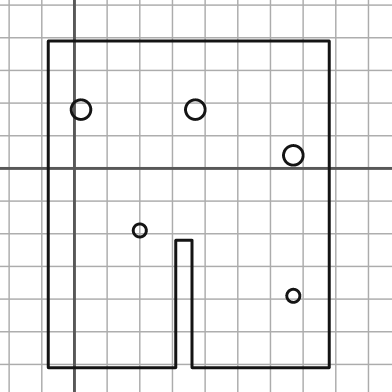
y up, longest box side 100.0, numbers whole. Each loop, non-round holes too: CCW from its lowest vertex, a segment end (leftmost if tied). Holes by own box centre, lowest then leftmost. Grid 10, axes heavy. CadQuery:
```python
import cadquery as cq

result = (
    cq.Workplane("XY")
    .moveTo(-8.0, -61.0)
    .lineTo(31.0, -61.0)
    .lineTo(31.0, -22.0)
    .lineTo(36.0, -22.0)
    .lineTo(36.0, -61.0)
    .lineTo(78.0, -61.0)
    .lineTo(78.0, 39.0)
    .lineTo(-8.0, 39.0)
    .close()
    .moveTo(67.0, -39.0)
    .circle(2.0)
    .moveTo(20.0, -19.0)
    .circle(2.0)
    .moveTo(67.0, 4.0)
    .circle(3.0)
    .moveTo(2.0, 18.0)
    .circle(3.0)
    .moveTo(37.0, 18.0)
    .circle(3.0)
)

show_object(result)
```